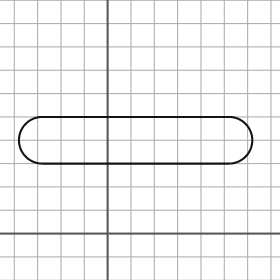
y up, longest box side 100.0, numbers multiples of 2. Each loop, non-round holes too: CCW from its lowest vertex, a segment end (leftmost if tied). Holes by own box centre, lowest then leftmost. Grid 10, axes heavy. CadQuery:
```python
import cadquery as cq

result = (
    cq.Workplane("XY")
    .moveTo(-28.0, 30.0)
    .lineTo(52.0, 30.0)
    .threePointArc((62.0, 40.0), (52.0, 50.0))
    .lineTo(-28.0, 50.0)
    .threePointArc((-38.0, 40.0), (-28.0, 30.0))
    .close()
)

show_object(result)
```